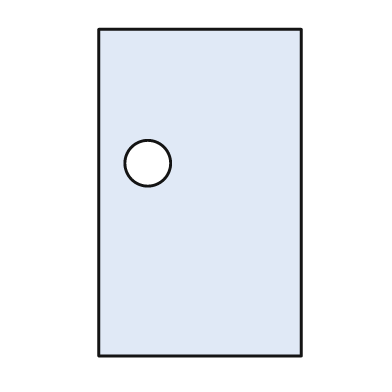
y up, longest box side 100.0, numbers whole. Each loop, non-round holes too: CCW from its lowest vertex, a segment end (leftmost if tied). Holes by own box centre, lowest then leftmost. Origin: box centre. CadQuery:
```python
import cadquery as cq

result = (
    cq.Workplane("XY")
    .moveTo(-31.0, -50.0)
    .lineTo(31.0, -50.0)
    .lineTo(31.0, 50.0)
    .lineTo(-31.0, 50.0)
    .close()
    .moveTo(-16.0, 9.0)
    .circle(7.0)
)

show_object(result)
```